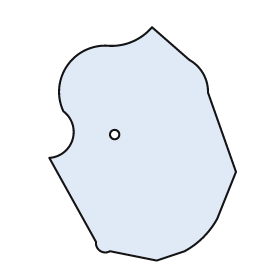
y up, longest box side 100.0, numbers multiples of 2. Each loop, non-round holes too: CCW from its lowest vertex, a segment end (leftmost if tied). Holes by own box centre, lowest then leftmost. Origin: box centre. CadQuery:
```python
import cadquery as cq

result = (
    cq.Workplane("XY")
    .moveTo(6.0, -50.0)
    .lineTo(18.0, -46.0)
    .threePointArc((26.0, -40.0), (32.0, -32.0))
    .lineTo(40.0, -12.0)
    .lineTo(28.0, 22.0)
    .threePointArc((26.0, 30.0), (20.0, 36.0))
    .lineTo(4.0, 50.0)
    .threePointArc((-4.0, 44.0), (-14.0, 42.0))
    .threePointArc((-32.0, 34.0), (-34.0, 14.0))
    .threePointArc((-30.0, 2.0), (-40.0, -6.0))
    .lineTo(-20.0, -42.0)
    .threePointArc((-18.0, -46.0), (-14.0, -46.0))
    .close()
    .moveTo(-12.0, 4.0)
    .circle(2.0)
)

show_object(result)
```